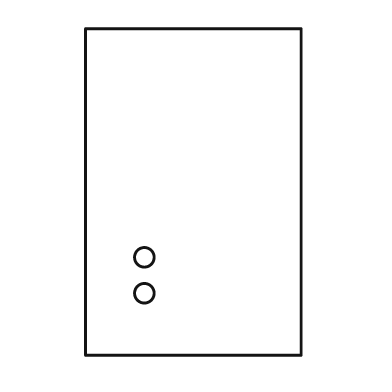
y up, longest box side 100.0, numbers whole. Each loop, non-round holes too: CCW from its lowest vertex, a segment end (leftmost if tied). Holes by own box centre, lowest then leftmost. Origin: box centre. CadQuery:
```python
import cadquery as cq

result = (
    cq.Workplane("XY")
    .moveTo(-33.0, -50.0)
    .lineTo(33.0, -50.0)
    .lineTo(33.0, 50.0)
    .lineTo(-33.0, 50.0)
    .close()
    .moveTo(-15.0, -31.0)
    .circle(3.0)
    .moveTo(-15.0, -20.0)
    .circle(3.0)
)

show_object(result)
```